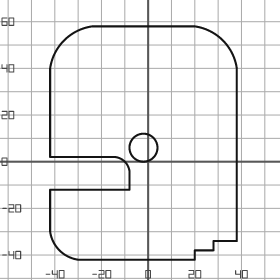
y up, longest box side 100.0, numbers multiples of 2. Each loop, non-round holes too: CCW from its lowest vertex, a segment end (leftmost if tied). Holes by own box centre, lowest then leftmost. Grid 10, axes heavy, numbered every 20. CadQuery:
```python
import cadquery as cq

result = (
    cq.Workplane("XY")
    .moveTo(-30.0, -42.0)
    .lineTo(20.0, -42.0)
    .lineTo(20.0, -38.0)
    .lineTo(28.0, -38.0)
    .lineTo(28.0, -34.0)
    .lineTo(38.0, -34.0)
    .lineTo(38.0, 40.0)
    .threePointArc((32.0, 52.0), (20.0, 58.0))
    .lineTo(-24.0, 58.0)
    .threePointArc((-36.0, 52.0), (-42.0, 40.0))
    .lineTo(-42.0, 2.0)
    .lineTo(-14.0, 2.0)
    .threePointArc((-10.0, 0.0), (-8.0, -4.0))
    .lineTo(-8.0, -12.0)
    .lineTo(-42.0, -12.0)
    .lineTo(-42.0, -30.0)
    .threePointArc((-38.0, -38.0), (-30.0, -42.0))
    .close()
    .moveTo(-2.0, 6.0)
    .circle(6.0)
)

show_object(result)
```